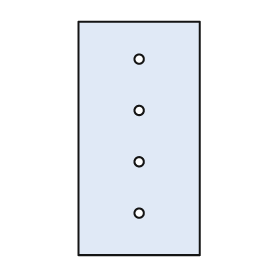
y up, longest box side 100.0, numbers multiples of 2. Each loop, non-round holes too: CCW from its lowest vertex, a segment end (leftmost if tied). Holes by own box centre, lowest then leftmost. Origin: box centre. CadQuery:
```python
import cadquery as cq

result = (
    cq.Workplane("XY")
    .moveTo(-26.0, -50.0)
    .lineTo(26.0, -50.0)
    .lineTo(26.0, 50.0)
    .lineTo(-26.0, 50.0)
    .close()
    .moveTo(0.0, -32.0)
    .circle(2.0)
    .moveTo(0.0, -10.0)
    .circle(2.0)
    .moveTo(0.0, 12.0)
    .circle(2.0)
    .moveTo(0.0, 34.0)
    .circle(2.0)
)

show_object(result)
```